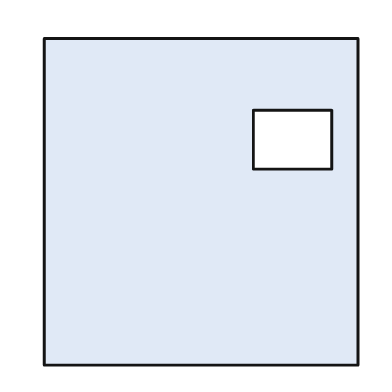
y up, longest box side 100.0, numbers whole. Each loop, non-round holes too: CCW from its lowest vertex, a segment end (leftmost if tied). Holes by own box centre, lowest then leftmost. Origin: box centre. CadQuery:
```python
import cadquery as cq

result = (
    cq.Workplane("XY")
    .moveTo(-48.0, -50.0)
    .lineTo(48.0, -50.0)
    .lineTo(48.0, 50.0)
    .lineTo(-48.0, 50.0)
    .close()
    .moveTo(16.0, 10.0)
    .lineTo(40.0, 10.0)
    .lineTo(40.0, 28.0)
    .lineTo(16.0, 28.0)
    .close()
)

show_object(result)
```